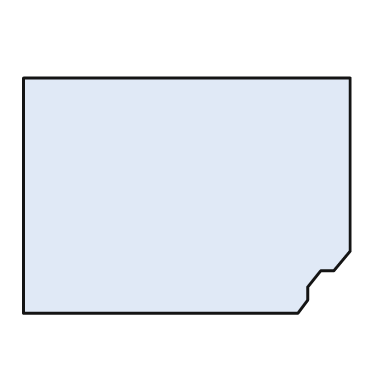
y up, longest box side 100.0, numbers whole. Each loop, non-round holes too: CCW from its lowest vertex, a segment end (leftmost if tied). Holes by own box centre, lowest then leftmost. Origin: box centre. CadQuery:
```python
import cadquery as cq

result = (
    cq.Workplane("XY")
    .moveTo(-50.0, -36.0)
    .lineTo(34.0, -36.0)
    .lineTo(37.0, -32.0)
    .lineTo(37.0, -28.0)
    .lineTo(41.0, -23.0)
    .lineTo(45.0, -23.0)
    .lineTo(50.0, -17.0)
    .lineTo(50.0, 36.0)
    .lineTo(-50.0, 36.0)
    .close()
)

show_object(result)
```